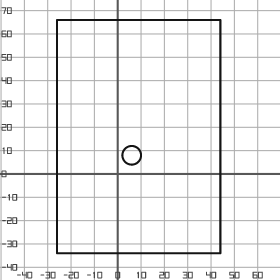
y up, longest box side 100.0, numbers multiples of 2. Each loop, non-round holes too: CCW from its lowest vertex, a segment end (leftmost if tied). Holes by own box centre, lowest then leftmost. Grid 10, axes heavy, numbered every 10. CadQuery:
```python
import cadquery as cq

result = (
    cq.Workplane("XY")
    .moveTo(-26.0, -34.0)
    .lineTo(44.0, -34.0)
    .lineTo(44.0, 66.0)
    .lineTo(-26.0, 66.0)
    .close()
    .moveTo(6.0, 8.0)
    .circle(4.0)
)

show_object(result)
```